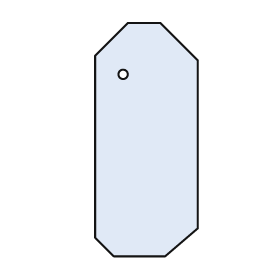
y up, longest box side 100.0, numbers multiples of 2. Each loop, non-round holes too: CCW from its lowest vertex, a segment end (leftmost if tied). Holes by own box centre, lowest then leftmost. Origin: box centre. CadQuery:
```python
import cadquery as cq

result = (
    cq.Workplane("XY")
    .moveTo(-14.0, -50.0)
    .lineTo(8.0, -50.0)
    .lineTo(22.0, -38.0)
    .lineTo(22.0, 34.0)
    .lineTo(6.0, 50.0)
    .lineTo(-8.0, 50.0)
    .lineTo(-22.0, 36.0)
    .lineTo(-22.0, -42.0)
    .close()
    .moveTo(-10.0, 28.0)
    .circle(2.0)
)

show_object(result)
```